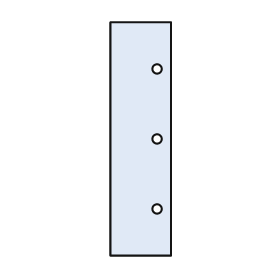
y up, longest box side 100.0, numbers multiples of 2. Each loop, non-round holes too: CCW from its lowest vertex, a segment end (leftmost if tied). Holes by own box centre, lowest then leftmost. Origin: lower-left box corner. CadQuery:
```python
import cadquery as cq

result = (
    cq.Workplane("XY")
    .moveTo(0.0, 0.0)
    .lineTo(26.0, 0.0)
    .lineTo(26.0, 100.0)
    .lineTo(0.0, 100.0)
    .close()
    .moveTo(20.0, 20.0)
    .circle(2.0)
    .moveTo(20.0, 50.0)
    .circle(2.0)
    .moveTo(20.0, 80.0)
    .circle(2.0)
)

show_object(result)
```